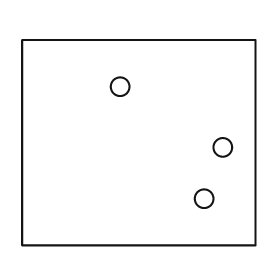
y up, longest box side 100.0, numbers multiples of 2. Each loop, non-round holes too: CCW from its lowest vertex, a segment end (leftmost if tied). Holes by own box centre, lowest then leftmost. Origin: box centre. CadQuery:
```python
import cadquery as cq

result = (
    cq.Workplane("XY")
    .moveTo(-50.0, -44.0)
    .lineTo(50.0, -44.0)
    .lineTo(50.0, 44.0)
    .lineTo(-50.0, 44.0)
    .close()
    .moveTo(28.0, -24.0)
    .circle(4.0)
    .moveTo(36.0, -2.0)
    .circle(4.0)
    .moveTo(-8.0, 24.0)
    .circle(4.0)
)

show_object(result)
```